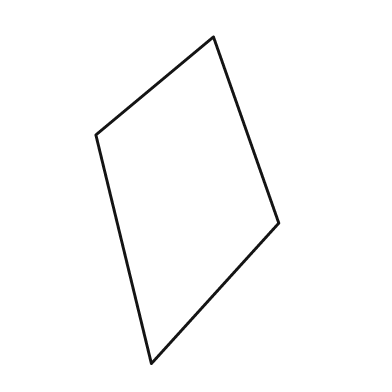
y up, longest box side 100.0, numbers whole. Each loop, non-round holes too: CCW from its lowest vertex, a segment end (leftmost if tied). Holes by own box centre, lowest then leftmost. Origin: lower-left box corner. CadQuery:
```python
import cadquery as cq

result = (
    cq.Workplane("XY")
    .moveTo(17.0, 0.0)
    .lineTo(56.0, 43.0)
    .lineTo(36.0, 100.0)
    .lineTo(0.0, 70.0)
    .close()
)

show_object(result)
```